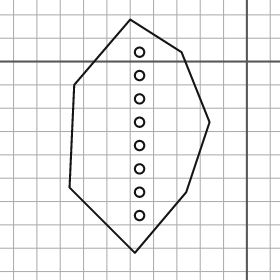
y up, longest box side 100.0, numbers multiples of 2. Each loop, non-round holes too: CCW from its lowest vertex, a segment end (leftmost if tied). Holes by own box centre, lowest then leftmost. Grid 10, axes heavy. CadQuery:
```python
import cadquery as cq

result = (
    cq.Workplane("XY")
    .moveTo(-48.0, -82.0)
    .lineTo(-26.0, -56.0)
    .lineTo(-16.0, -26.0)
    .lineTo(-28.0, 4.0)
    .lineTo(-50.0, 18.0)
    .lineTo(-74.0, -10.0)
    .lineTo(-76.0, -54.0)
    .close()
    .moveTo(-46.0, -66.0)
    .circle(2.0)
    .moveTo(-46.0, -56.0)
    .circle(2.0)
    .moveTo(-46.0, -46.0)
    .circle(2.0)
    .moveTo(-46.0, -36.0)
    .circle(2.0)
    .moveTo(-46.0, -26.0)
    .circle(2.0)
    .moveTo(-46.0, -16.0)
    .circle(2.0)
    .moveTo(-46.0, -6.0)
    .circle(2.0)
    .moveTo(-46.0, 4.0)
    .circle(2.0)
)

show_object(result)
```